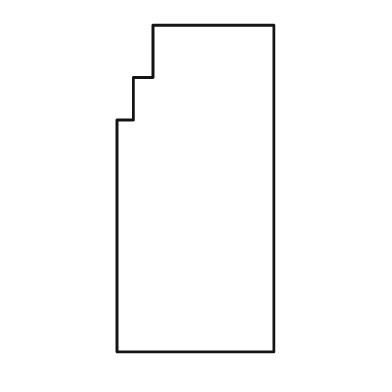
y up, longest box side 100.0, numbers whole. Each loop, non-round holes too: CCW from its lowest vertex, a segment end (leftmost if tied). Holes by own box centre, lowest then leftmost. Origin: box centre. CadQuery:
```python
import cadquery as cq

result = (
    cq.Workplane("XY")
    .moveTo(-24.0, -50.0)
    .lineTo(24.0, -50.0)
    .lineTo(24.0, 50.0)
    .lineTo(-13.0, 50.0)
    .lineTo(-13.0, 34.0)
    .lineTo(-19.0, 34.0)
    .lineTo(-19.0, 21.0)
    .lineTo(-24.0, 21.0)
    .close()
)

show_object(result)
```